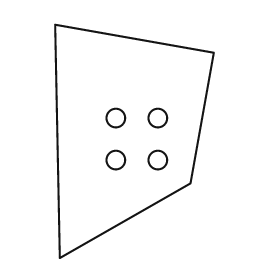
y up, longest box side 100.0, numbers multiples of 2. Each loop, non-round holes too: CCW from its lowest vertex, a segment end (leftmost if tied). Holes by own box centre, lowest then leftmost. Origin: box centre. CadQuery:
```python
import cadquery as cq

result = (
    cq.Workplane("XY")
    .moveTo(-32.0, -50.0)
    .lineTo(24.0, -18.0)
    .lineTo(34.0, 38.0)
    .lineTo(-34.0, 50.0)
    .close()
    .moveTo(-8.0, -8.0)
    .circle(4.0)
    .moveTo(10.0, -8.0)
    .circle(4.0)
    .moveTo(-8.0, 10.0)
    .circle(4.0)
    .moveTo(10.0, 10.0)
    .circle(4.0)
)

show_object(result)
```